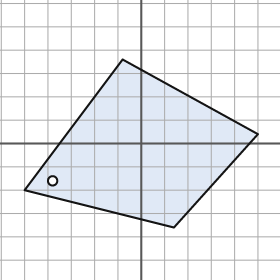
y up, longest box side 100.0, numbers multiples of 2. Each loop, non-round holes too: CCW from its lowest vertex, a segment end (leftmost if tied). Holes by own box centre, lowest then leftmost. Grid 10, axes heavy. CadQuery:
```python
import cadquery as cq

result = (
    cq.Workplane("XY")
    .moveTo(14.0, -36.0)
    .lineTo(50.0, 4.0)
    .lineTo(-8.0, 36.0)
    .lineTo(-50.0, -20.0)
    .close()
    .moveTo(-38.0, -16.0)
    .circle(2.0)
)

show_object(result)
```